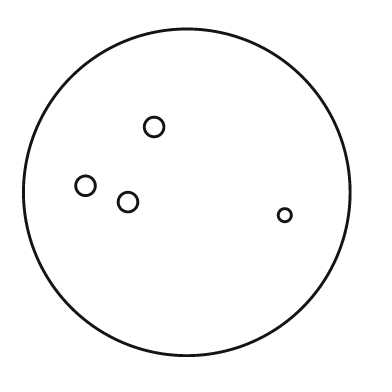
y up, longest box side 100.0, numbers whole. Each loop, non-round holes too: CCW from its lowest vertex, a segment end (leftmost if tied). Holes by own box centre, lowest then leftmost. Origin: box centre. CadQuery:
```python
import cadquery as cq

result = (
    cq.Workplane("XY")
    .moveTo(0.0, 0.0)
    .circle(50.0)
    .moveTo(30.0, -7.0)
    .circle(2.0)
    .moveTo(-18.0, -3.0)
    .circle(3.0)
    .moveTo(-31.0, 2.0)
    .circle(3.0)
    .moveTo(-10.0, 20.0)
    .circle(3.0)
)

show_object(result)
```